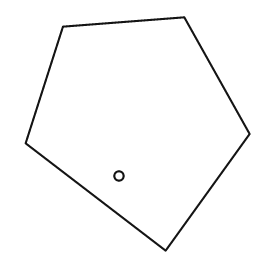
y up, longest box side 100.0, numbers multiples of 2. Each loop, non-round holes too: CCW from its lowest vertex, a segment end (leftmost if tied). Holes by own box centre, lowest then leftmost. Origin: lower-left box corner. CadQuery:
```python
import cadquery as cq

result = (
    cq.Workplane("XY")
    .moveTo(60.0, 0.0)
    .lineTo(96.0, 50.0)
    .lineTo(68.0, 100.0)
    .lineTo(16.0, 96.0)
    .lineTo(0.0, 46.0)
    .close()
    .moveTo(40.0, 32.0)
    .circle(2.0)
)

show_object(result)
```